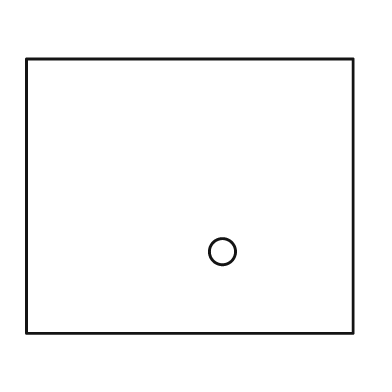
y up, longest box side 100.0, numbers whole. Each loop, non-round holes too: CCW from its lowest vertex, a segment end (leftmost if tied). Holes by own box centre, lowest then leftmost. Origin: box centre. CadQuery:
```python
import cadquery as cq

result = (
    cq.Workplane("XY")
    .moveTo(-50.0, -42.0)
    .lineTo(50.0, -42.0)
    .lineTo(50.0, 42.0)
    .lineTo(-50.0, 42.0)
    .close()
    .moveTo(10.0, -17.0)
    .circle(4.0)
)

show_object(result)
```